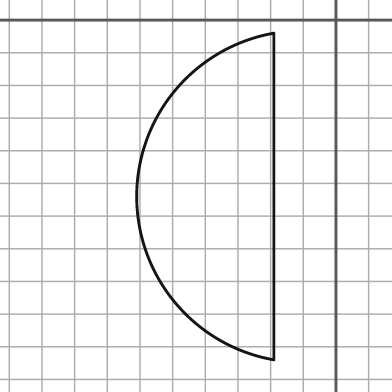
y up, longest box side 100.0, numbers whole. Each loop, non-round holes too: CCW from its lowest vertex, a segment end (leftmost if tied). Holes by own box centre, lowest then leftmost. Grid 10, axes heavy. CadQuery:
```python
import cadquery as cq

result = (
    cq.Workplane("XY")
    .moveTo(-19.0, -104.0)
    .lineTo(-19.0, -4.0)
    .threePointArc((-61.0, -54.0), (-19.0, -104.0))
    .close()
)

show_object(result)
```